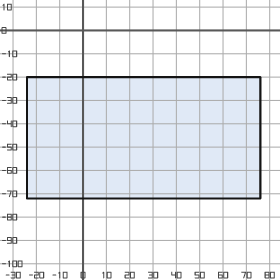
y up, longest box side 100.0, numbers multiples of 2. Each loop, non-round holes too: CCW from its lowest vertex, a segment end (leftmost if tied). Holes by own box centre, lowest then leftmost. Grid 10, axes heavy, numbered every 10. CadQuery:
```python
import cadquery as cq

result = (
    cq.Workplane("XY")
    .moveTo(-24.0, -72.0)
    .lineTo(76.0, -72.0)
    .lineTo(76.0, -20.0)
    .lineTo(-24.0, -20.0)
    .close()
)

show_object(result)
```